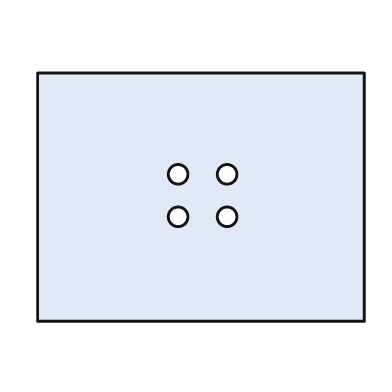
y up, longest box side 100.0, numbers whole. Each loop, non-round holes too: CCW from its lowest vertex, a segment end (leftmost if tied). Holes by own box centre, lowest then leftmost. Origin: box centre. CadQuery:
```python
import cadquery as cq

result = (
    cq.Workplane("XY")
    .moveTo(-50.0, -38.0)
    .lineTo(50.0, -38.0)
    .lineTo(50.0, 38.0)
    .lineTo(-50.0, 38.0)
    .close()
    .moveTo(-7.0, -6.0)
    .circle(3.0)
    .moveTo(8.0, -6.0)
    .circle(3.0)
    .moveTo(-7.0, 7.0)
    .circle(3.0)
    .moveTo(8.0, 7.0)
    .circle(3.0)
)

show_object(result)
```